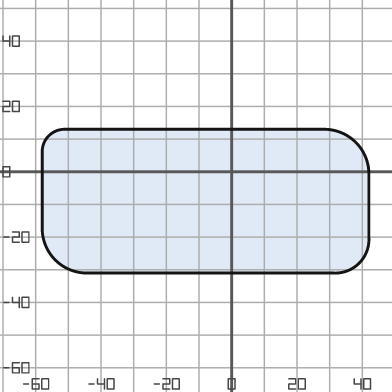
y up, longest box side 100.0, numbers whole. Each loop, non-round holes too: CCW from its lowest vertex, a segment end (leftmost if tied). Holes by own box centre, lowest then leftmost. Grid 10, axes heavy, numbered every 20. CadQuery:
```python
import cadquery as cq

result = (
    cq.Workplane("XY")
    .moveTo(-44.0, -31.0)
    .lineTo(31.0, -31.0)
    .threePointArc((39.0, -28.0), (42.0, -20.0))
    .lineTo(42.0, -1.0)
    .threePointArc((38.0, 9.0), (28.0, 13.0))
    .lineTo(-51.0, 13.0)
    .threePointArc((-56.0, 11.0), (-58.0, 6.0))
    .lineTo(-58.0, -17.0)
    .threePointArc((-54.0, -27.0), (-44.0, -31.0))
    .close()
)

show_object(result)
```